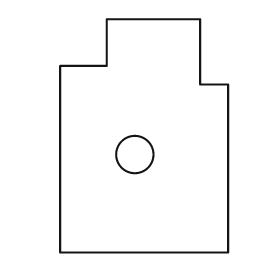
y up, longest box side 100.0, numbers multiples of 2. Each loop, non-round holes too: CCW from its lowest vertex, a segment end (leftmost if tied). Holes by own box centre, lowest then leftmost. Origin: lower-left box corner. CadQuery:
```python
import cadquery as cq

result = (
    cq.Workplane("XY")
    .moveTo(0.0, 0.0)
    .lineTo(72.0, 0.0)
    .lineTo(72.0, 72.0)
    .lineTo(60.0, 72.0)
    .lineTo(60.0, 100.0)
    .lineTo(20.0, 100.0)
    .lineTo(20.0, 80.0)
    .lineTo(0.0, 80.0)
    .close()
    .moveTo(32.0, 42.0)
    .circle(8.0)
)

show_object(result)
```